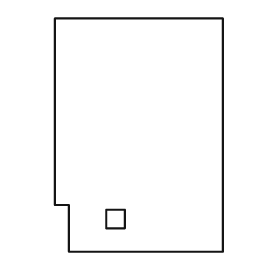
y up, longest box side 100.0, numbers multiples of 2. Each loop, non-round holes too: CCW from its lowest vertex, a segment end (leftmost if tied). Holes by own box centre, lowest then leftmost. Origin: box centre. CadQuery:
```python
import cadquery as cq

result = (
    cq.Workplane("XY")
    .moveTo(-30.0, -50.0)
    .lineTo(36.0, -50.0)
    .lineTo(36.0, 50.0)
    .lineTo(-36.0, 50.0)
    .lineTo(-36.0, -30.0)
    .lineTo(-30.0, -30.0)
    .close()
    .moveTo(-14.0, -40.0)
    .lineTo(-6.0, -40.0)
    .lineTo(-6.0, -32.0)
    .lineTo(-14.0, -32.0)
    .close()
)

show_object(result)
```